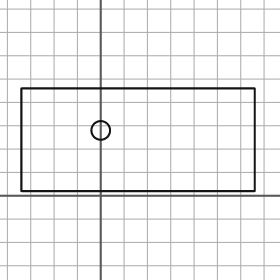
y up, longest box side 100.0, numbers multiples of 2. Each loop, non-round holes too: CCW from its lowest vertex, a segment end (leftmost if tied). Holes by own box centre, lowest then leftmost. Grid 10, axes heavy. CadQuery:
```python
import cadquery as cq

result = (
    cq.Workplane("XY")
    .moveTo(-34.0, 2.0)
    .lineTo(66.0, 2.0)
    .lineTo(66.0, 46.0)
    .lineTo(-34.0, 46.0)
    .close()
    .moveTo(0.0, 28.0)
    .circle(4.0)
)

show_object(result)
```